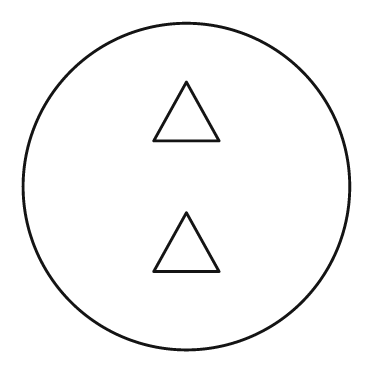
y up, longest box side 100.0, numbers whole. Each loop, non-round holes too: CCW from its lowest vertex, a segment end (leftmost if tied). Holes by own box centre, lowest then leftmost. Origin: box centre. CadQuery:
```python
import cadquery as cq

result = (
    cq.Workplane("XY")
    .moveTo(0.0, 0.0)
    .circle(50.0)
    .moveTo(-10.0, -26.0)
    .lineTo(10.0, -26.0)
    .lineTo(0.0, -8.0)
    .close()
    .moveTo(-10.0, 14.0)
    .lineTo(10.0, 14.0)
    .lineTo(0.0, 32.0)
    .close()
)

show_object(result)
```